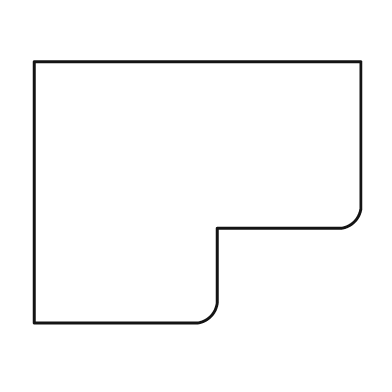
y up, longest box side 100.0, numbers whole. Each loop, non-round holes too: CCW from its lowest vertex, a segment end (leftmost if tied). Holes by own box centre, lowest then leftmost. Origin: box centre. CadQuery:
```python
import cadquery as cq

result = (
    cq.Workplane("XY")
    .moveTo(-50.0, -40.0)
    .lineTo(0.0, -40.0)
    .threePointArc((4.0, -38.0), (6.0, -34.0))
    .lineTo(6.0, -11.0)
    .lineTo(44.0, -11.0)
    .threePointArc((48.0, -9.0), (50.0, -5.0))
    .lineTo(50.0, 40.0)
    .lineTo(-50.0, 40.0)
    .close()
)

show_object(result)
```